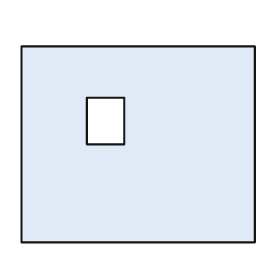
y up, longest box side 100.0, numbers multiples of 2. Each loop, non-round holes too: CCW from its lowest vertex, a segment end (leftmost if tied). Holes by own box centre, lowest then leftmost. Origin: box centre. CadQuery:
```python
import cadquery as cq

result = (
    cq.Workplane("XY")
    .moveTo(-50.0, -42.0)
    .lineTo(50.0, -42.0)
    .lineTo(50.0, 42.0)
    .lineTo(-50.0, 42.0)
    .close()
    .moveTo(-22.0, 0.0)
    .lineTo(-6.0, 0.0)
    .lineTo(-6.0, 20.0)
    .lineTo(-22.0, 20.0)
    .close()
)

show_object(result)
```